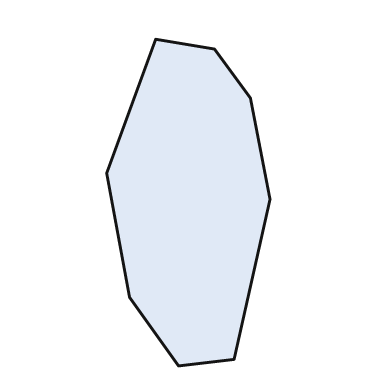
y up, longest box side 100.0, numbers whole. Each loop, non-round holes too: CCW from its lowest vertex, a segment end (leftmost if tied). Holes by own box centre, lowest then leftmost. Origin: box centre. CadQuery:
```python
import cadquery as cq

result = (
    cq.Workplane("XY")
    .moveTo(-3.0, -50.0)
    .lineTo(14.0, -48.0)
    .lineTo(25.0, 1.0)
    .lineTo(19.0, 32.0)
    .lineTo(8.0, 47.0)
    .lineTo(-10.0, 50.0)
    .lineTo(-25.0, 9.0)
    .lineTo(-18.0, -29.0)
    .close()
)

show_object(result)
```